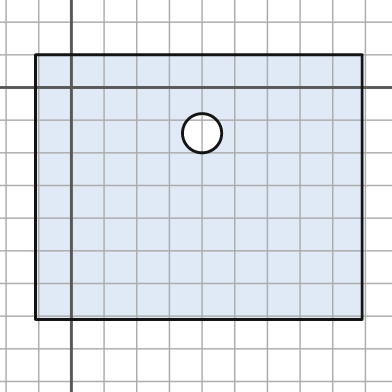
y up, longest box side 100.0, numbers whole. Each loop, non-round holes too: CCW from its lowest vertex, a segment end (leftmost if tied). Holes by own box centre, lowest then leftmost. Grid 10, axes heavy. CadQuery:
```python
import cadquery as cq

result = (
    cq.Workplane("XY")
    .moveTo(-11.0, -71.0)
    .lineTo(89.0, -71.0)
    .lineTo(89.0, 10.0)
    .lineTo(-11.0, 10.0)
    .close()
    .moveTo(40.0, -14.0)
    .circle(6.0)
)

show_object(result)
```